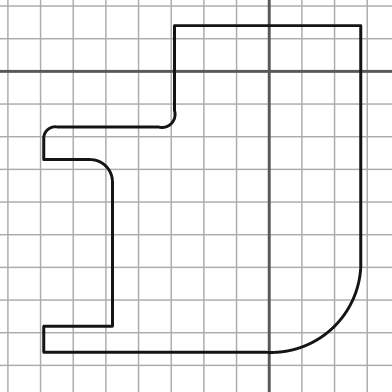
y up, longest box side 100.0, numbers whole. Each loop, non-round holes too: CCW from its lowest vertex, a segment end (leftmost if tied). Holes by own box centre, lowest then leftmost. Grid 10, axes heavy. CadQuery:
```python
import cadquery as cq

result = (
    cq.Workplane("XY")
    .moveTo(-69.0, -86.0)
    .lineTo(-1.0, -86.0)
    .threePointArc((20.0, -78.0), (28.0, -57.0))
    .lineTo(28.0, 14.0)
    .lineTo(-29.0, 14.0)
    .lineTo(-29.0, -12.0)
    .threePointArc((-30.0, -16.0), (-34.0, -17.0))
    .lineTo(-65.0, -17.0)
    .threePointArc((-68.0, -18.0), (-69.0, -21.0))
    .lineTo(-69.0, -27.0)
    .lineTo(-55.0, -27.0)
    .threePointArc((-50.0, -29.0), (-48.0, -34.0))
    .lineTo(-48.0, -78.0)
    .lineTo(-69.0, -78.0)
    .close()
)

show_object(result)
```